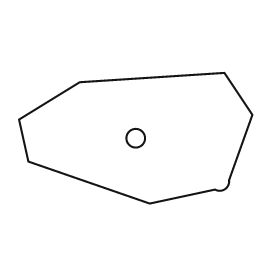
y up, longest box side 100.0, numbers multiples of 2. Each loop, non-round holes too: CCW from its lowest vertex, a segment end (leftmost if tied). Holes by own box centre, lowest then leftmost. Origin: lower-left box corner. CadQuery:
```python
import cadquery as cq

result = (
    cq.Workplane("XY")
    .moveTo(56.0, 0.0)
    .lineTo(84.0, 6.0)
    .threePointArc((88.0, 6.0), (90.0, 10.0))
    .lineTo(100.0, 38.0)
    .lineTo(88.0, 56.0)
    .lineTo(26.0, 52.0)
    .lineTo(0.0, 36.0)
    .lineTo(4.0, 18.0)
    .close()
    .moveTo(50.0, 28.0)
    .circle(4.0)
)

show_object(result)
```